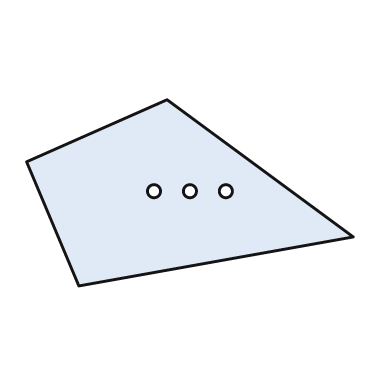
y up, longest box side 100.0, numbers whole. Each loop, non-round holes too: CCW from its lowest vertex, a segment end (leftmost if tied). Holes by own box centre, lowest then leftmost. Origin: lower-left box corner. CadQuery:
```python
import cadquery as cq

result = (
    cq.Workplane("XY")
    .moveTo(16.0, 0.0)
    .lineTo(100.0, 15.0)
    .lineTo(43.0, 57.0)
    .lineTo(0.0, 38.0)
    .close()
    .moveTo(39.0, 29.0)
    .circle(2.0)
    .moveTo(50.0, 29.0)
    .circle(2.0)
    .moveTo(61.0, 29.0)
    .circle(2.0)
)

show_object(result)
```